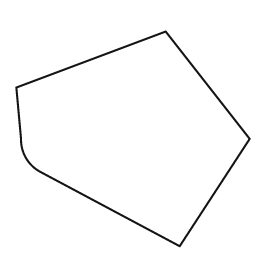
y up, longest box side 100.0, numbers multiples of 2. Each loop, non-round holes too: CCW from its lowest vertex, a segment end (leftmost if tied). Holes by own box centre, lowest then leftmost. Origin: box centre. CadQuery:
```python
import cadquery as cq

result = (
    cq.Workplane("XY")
    .moveTo(20.0, -46.0)
    .lineTo(50.0, 0.0)
    .lineTo(14.0, 46.0)
    .lineTo(-50.0, 22.0)
    .lineTo(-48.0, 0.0)
    .threePointArc((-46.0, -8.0), (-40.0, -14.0))
    .close()
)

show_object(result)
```